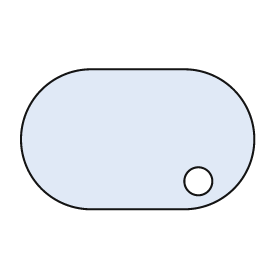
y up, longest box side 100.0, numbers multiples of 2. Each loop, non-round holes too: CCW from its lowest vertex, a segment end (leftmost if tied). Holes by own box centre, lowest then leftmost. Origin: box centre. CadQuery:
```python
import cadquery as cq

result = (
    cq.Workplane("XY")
    .moveTo(-20.0, -30.0)
    .lineTo(20.0, -30.0)
    .threePointArc((50.0, 0.0), (20.0, 30.0))
    .lineTo(-20.0, 30.0)
    .threePointArc((-50.0, 0.0), (-20.0, -30.0))
    .close()
    .moveTo(26.0, -18.0)
    .circle(6.0)
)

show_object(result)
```